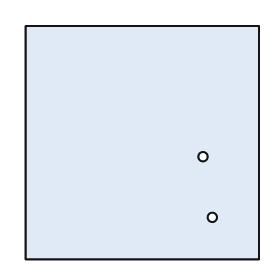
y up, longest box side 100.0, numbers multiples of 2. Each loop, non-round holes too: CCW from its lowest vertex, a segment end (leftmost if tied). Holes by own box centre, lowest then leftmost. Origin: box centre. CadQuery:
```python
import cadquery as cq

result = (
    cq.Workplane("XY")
    .moveTo(-50.0, -50.0)
    .lineTo(50.0, -50.0)
    .lineTo(50.0, 50.0)
    .lineTo(-50.0, 50.0)
    .close()
    .moveTo(30.0, -32.0)
    .circle(2.0)
    .moveTo(26.0, -6.0)
    .circle(2.0)
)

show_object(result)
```